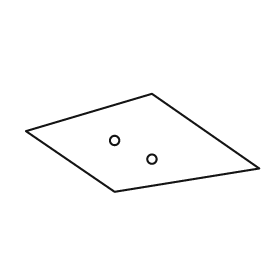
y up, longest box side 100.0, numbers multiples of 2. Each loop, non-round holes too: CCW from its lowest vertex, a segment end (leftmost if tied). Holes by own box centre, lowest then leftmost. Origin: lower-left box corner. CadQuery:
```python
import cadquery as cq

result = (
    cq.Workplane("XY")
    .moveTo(38.0, 0.0)
    .lineTo(100.0, 10.0)
    .lineTo(54.0, 42.0)
    .lineTo(0.0, 26.0)
    .close()
    .moveTo(54.0, 14.0)
    .circle(2.0)
    .moveTo(38.0, 22.0)
    .circle(2.0)
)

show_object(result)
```